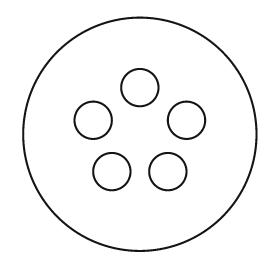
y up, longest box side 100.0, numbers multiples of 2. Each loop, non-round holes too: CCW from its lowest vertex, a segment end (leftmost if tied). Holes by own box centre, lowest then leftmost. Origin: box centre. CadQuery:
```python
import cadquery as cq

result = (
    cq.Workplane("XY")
    .moveTo(0.0, 0.0)
    .circle(50.0)
    .moveTo(-12.0, -16.0)
    .circle(8.0)
    .moveTo(12.0, -16.0)
    .circle(8.0)
    .moveTo(-20.0, 6.0)
    .circle(8.0)
    .moveTo(20.0, 6.0)
    .circle(8.0)
    .moveTo(0.0, 20.0)
    .circle(8.0)
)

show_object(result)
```